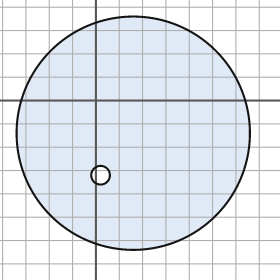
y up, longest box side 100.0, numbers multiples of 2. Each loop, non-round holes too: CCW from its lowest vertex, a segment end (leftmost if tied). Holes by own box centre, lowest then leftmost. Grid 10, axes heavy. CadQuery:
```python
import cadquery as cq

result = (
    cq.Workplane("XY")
    .moveTo(16.0, -14.0)
    .circle(50.0)
    .moveTo(2.0, -32.0)
    .circle(4.0)
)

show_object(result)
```